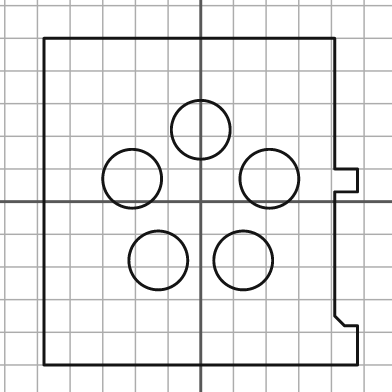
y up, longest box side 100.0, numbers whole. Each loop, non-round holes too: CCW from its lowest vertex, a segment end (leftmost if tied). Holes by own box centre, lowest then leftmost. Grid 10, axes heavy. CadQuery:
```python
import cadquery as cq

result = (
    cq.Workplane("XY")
    .moveTo(-48.0, -50.0)
    .lineTo(48.0, -50.0)
    .lineTo(48.0, -38.0)
    .lineTo(44.0, -38.0)
    .lineTo(41.0, -35.0)
    .lineTo(41.0, 3.0)
    .lineTo(48.0, 3.0)
    .lineTo(48.0, 10.0)
    .lineTo(41.0, 10.0)
    .lineTo(41.0, 50.0)
    .lineTo(-48.0, 50.0)
    .close()
    .moveTo(-13.0, -18.0)
    .circle(9.0)
    .moveTo(13.0, -18.0)
    .circle(9.0)
    .moveTo(-21.0, 7.0)
    .circle(9.0)
    .moveTo(21.0, 7.0)
    .circle(9.0)
    .moveTo(0.0, 22.0)
    .circle(9.0)
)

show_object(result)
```